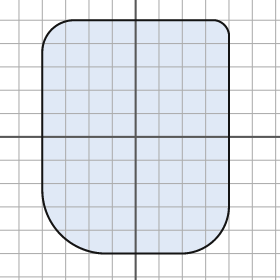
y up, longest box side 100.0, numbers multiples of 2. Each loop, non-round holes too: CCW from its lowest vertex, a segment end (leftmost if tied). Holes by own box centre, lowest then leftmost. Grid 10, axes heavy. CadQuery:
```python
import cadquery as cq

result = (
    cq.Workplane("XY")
    .moveTo(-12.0, -50.0)
    .lineTo(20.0, -50.0)
    .threePointArc((34.0, -44.0), (40.0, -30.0))
    .lineTo(40.0, 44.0)
    .threePointArc((38.0, 48.0), (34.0, 50.0))
    .lineTo(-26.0, 50.0)
    .threePointArc((-36.0, 46.0), (-40.0, 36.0))
    .lineTo(-40.0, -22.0)
    .threePointArc((-32.0, -42.0), (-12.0, -50.0))
    .close()
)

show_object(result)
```